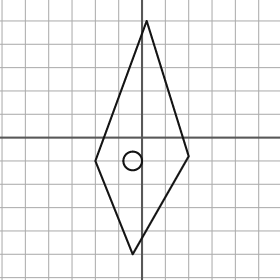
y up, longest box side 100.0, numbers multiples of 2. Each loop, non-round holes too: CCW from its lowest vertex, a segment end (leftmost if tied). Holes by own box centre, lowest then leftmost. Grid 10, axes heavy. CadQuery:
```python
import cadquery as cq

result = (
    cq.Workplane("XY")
    .moveTo(-4.0, -50.0)
    .lineTo(20.0, -8.0)
    .lineTo(2.0, 50.0)
    .lineTo(-20.0, -10.0)
    .close()
    .moveTo(-4.0, -10.0)
    .circle(4.0)
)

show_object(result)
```